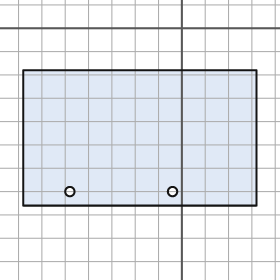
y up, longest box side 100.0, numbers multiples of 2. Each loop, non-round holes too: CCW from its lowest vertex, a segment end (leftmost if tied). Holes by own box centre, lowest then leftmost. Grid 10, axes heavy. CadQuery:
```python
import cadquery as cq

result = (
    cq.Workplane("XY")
    .moveTo(-68.0, -76.0)
    .lineTo(32.0, -76.0)
    .lineTo(32.0, -18.0)
    .lineTo(-68.0, -18.0)
    .close()
    .moveTo(-48.0, -70.0)
    .circle(2.0)
    .moveTo(-4.0, -70.0)
    .circle(2.0)
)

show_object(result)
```